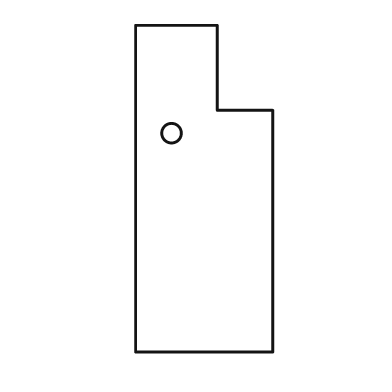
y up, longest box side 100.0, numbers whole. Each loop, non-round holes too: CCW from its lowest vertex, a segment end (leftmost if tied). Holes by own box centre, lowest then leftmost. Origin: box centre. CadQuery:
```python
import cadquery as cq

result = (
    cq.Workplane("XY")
    .moveTo(-21.0, -50.0)
    .lineTo(21.0, -50.0)
    .lineTo(21.0, 24.0)
    .lineTo(4.0, 24.0)
    .lineTo(4.0, 50.0)
    .lineTo(-21.0, 50.0)
    .close()
    .moveTo(-10.0, 17.0)
    .circle(3.0)
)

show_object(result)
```